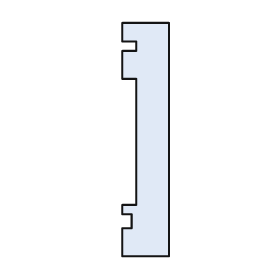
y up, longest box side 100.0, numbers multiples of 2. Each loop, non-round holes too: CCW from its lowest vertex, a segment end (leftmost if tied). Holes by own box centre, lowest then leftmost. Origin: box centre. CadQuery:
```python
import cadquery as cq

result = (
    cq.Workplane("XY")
    .moveTo(-10.0, -50.0)
    .lineTo(10.0, -50.0)
    .lineTo(10.0, 50.0)
    .lineTo(-10.0, 50.0)
    .lineTo(-10.0, 42.0)
    .lineTo(-4.0, 42.0)
    .lineTo(-4.0, 38.0)
    .lineTo(-10.0, 38.0)
    .lineTo(-10.0, 26.0)
    .lineTo(-4.0, 26.0)
    .lineTo(-4.0, -28.0)
    .lineTo(-10.0, -28.0)
    .lineTo(-10.0, -32.0)
    .lineTo(-6.0, -32.0)
    .lineTo(-6.0, -38.0)
    .lineTo(-10.0, -38.0)
    .close()
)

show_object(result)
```